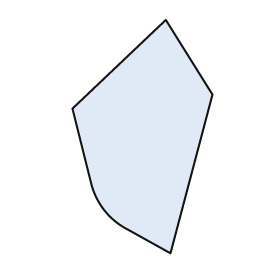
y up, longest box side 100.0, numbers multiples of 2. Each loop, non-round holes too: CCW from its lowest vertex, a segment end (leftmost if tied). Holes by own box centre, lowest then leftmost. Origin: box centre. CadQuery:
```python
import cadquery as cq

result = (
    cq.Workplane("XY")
    .moveTo(12.0, -50.0)
    .lineTo(30.0, 18.0)
    .lineTo(10.0, 50.0)
    .lineTo(-30.0, 12.0)
    .lineTo(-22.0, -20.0)
    .threePointArc((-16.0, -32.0), (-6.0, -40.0))
    .close()
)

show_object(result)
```